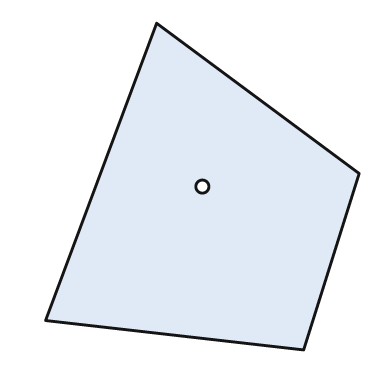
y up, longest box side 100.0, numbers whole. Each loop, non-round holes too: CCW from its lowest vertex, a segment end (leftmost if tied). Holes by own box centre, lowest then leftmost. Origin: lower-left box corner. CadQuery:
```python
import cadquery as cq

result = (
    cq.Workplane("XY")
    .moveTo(79.0, 0.0)
    .lineTo(96.0, 54.0)
    .lineTo(34.0, 100.0)
    .lineTo(0.0, 9.0)
    .close()
    .moveTo(48.0, 50.0)
    .circle(2.0)
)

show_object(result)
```